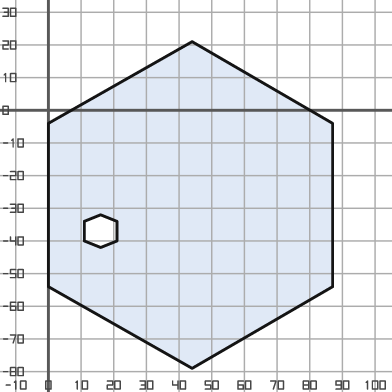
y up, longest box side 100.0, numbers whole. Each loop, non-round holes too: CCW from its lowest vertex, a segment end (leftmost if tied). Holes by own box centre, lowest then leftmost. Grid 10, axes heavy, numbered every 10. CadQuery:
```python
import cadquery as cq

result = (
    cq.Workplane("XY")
    .moveTo(44.0, -79.0)
    .lineTo(87.0, -54.0)
    .lineTo(87.0, -4.0)
    .lineTo(44.0, 21.0)
    .lineTo(0.0, -4.0)
    .lineTo(0.0, -54.0)
    .close()
    .moveTo(16.0, -42.0)
    .lineTo(21.0, -40.0)
    .lineTo(21.0, -34.0)
    .lineTo(16.0, -32.0)
    .lineTo(11.0, -34.0)
    .lineTo(11.0, -40.0)
    .close()
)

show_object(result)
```